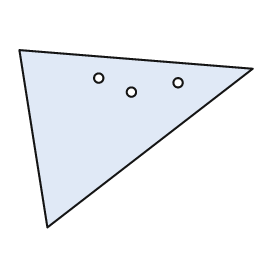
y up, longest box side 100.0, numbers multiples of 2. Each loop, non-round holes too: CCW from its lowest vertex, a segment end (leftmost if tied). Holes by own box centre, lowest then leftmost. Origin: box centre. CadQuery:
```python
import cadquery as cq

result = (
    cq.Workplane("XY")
    .moveTo(-38.0, -38.0)
    .lineTo(50.0, 30.0)
    .lineTo(-50.0, 38.0)
    .close()
    .moveTo(-2.0, 20.0)
    .circle(2.0)
    .moveTo(18.0, 24.0)
    .circle(2.0)
    .moveTo(-16.0, 26.0)
    .circle(2.0)
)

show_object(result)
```